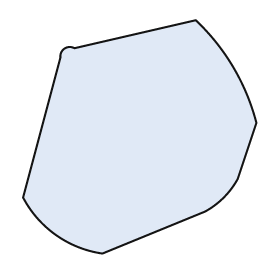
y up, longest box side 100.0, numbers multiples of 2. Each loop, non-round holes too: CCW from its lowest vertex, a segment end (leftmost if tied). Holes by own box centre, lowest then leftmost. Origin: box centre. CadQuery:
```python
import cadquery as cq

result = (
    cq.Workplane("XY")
    .moveTo(-16.0, -50.0)
    .lineTo(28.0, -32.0)
    .threePointArc((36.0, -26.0), (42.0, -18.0))
    .lineTo(50.0, 6.0)
    .threePointArc((40.0, 30.0), (24.0, 50.0))
    .lineTo(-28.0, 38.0)
    .threePointArc((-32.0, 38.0), (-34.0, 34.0))
    .lineTo(-50.0, -26.0)
    .threePointArc((-36.0, -42.0), (-16.0, -50.0))
    .close()
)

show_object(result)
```